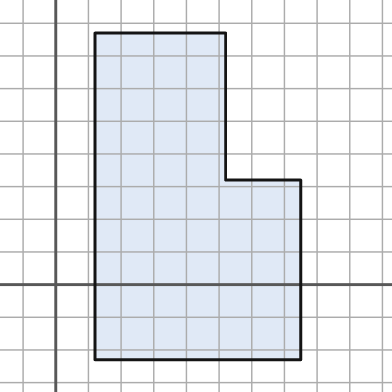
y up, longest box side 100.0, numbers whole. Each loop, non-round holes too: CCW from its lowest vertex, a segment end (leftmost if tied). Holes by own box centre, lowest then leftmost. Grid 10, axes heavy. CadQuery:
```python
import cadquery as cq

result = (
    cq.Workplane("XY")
    .moveTo(12.0, -23.0)
    .lineTo(75.0, -23.0)
    .lineTo(75.0, 32.0)
    .lineTo(52.0, 32.0)
    .lineTo(52.0, 77.0)
    .lineTo(12.0, 77.0)
    .close()
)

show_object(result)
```